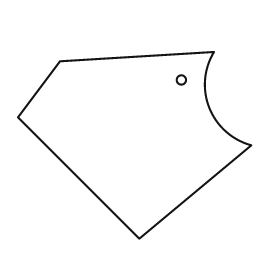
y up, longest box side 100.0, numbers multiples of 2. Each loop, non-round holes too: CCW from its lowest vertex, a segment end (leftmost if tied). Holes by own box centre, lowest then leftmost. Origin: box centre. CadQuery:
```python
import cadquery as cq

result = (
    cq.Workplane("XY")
    .moveTo(2.0, -40.0)
    .lineTo(50.0, 0.0)
    .threePointArc((32.0, 16.0), (34.0, 40.0))
    .lineTo(-32.0, 36.0)
    .lineTo(-50.0, 12.0)
    .close()
    .moveTo(20.0, 28.0)
    .circle(2.0)
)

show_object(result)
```